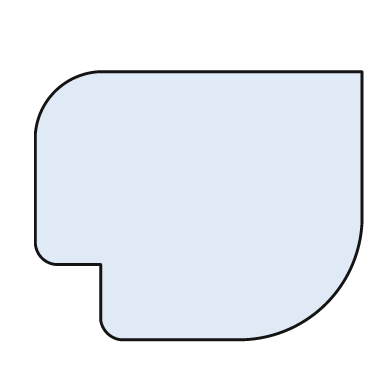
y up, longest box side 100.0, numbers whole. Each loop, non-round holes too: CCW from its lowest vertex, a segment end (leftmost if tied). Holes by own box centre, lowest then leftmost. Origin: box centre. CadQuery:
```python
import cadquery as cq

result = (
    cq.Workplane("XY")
    .moveTo(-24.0, -41.0)
    .lineTo(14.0, -41.0)
    .threePointArc((39.0, -30.0), (50.0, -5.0))
    .lineTo(50.0, 41.0)
    .lineTo(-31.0, 41.0)
    .threePointArc((-44.0, 35.0), (-50.0, 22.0))
    .lineTo(-50.0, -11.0)
    .threePointArc((-48.0, -16.0), (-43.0, -18.0))
    .lineTo(-30.0, -18.0)
    .lineTo(-30.0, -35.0)
    .threePointArc((-28.0, -39.0), (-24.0, -41.0))
    .close()
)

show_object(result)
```